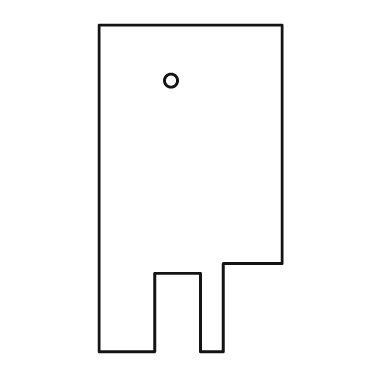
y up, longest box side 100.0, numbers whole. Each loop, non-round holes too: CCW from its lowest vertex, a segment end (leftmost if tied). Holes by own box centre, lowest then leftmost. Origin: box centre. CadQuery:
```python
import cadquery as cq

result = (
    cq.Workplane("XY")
    .moveTo(-28.0, -50.0)
    .lineTo(-11.0, -50.0)
    .lineTo(-11.0, -26.0)
    .lineTo(3.0, -26.0)
    .lineTo(3.0, -50.0)
    .lineTo(10.0, -50.0)
    .lineTo(10.0, -23.0)
    .lineTo(28.0, -23.0)
    .lineTo(28.0, 50.0)
    .lineTo(-28.0, 50.0)
    .close()
    .moveTo(-6.0, 33.0)
    .circle(2.0)
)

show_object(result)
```